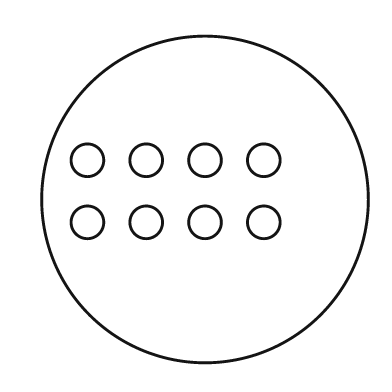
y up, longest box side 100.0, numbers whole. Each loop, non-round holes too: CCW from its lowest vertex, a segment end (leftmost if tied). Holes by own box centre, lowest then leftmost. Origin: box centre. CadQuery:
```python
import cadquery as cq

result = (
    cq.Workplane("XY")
    .moveTo(0.0, 0.0)
    .circle(50.0)
    .moveTo(-36.0, -7.0)
    .circle(5.0)
    .moveTo(-18.0, -7.0)
    .circle(5.0)
    .moveTo(0.0, -7.0)
    .circle(5.0)
    .moveTo(18.0, -7.0)
    .circle(5.0)
    .moveTo(-36.0, 12.0)
    .circle(5.0)
    .moveTo(-18.0, 12.0)
    .circle(5.0)
    .moveTo(0.0, 12.0)
    .circle(5.0)
    .moveTo(18.0, 12.0)
    .circle(5.0)
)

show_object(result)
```